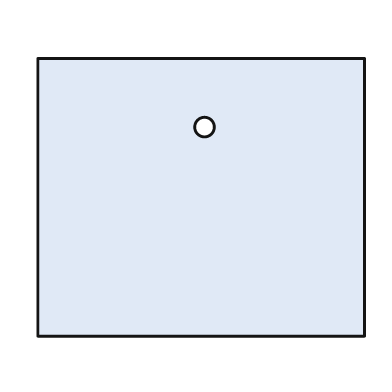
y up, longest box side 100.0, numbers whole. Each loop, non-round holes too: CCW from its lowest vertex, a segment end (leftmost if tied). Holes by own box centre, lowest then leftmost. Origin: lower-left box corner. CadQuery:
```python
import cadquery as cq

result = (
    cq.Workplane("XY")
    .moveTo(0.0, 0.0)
    .lineTo(100.0, 0.0)
    .lineTo(100.0, 85.0)
    .lineTo(0.0, 85.0)
    .close()
    .moveTo(51.0, 64.0)
    .circle(3.0)
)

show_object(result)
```